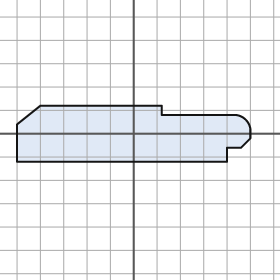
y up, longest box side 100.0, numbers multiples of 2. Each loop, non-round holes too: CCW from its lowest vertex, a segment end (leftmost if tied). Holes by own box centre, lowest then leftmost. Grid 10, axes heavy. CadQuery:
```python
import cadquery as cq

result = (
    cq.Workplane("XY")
    .moveTo(-50.0, -12.0)
    .lineTo(40.0, -12.0)
    .lineTo(40.0, -6.0)
    .lineTo(46.0, -6.0)
    .lineTo(50.0, -2.0)
    .lineTo(50.0, 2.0)
    .threePointArc((48.0, 6.0), (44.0, 8.0))
    .lineTo(12.0, 8.0)
    .lineTo(12.0, 12.0)
    .lineTo(-40.0, 12.0)
    .lineTo(-50.0, 4.0)
    .close()
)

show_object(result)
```